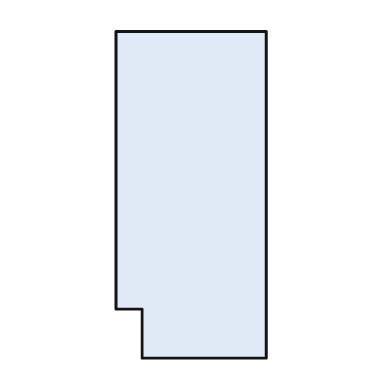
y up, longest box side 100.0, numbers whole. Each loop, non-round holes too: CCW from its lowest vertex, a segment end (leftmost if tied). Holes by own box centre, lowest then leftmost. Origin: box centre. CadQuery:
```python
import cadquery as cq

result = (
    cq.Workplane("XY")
    .moveTo(-15.0, -50.0)
    .lineTo(23.0, -50.0)
    .lineTo(23.0, 50.0)
    .lineTo(-23.0, 50.0)
    .lineTo(-23.0, -35.0)
    .lineTo(-15.0, -35.0)
    .close()
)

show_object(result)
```